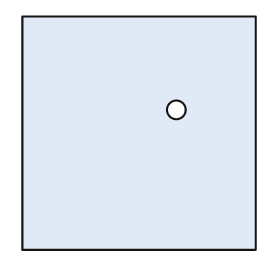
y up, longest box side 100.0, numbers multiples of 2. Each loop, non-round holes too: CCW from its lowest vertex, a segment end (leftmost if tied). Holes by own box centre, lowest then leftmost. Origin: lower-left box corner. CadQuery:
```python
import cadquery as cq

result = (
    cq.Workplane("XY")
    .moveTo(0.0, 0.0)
    .lineTo(100.0, 0.0)
    .lineTo(100.0, 100.0)
    .lineTo(0.0, 100.0)
    .close()
    .moveTo(66.0, 60.0)
    .circle(4.0)
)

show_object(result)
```